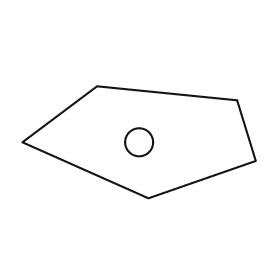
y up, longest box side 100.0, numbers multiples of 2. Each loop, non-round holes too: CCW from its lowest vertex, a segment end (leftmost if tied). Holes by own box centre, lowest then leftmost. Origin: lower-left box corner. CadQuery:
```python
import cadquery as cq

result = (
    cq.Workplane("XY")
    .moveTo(54.0, 0.0)
    .lineTo(100.0, 16.0)
    .lineTo(92.0, 42.0)
    .lineTo(32.0, 48.0)
    .lineTo(0.0, 24.0)
    .close()
    .moveTo(50.0, 24.0)
    .circle(6.0)
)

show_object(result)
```